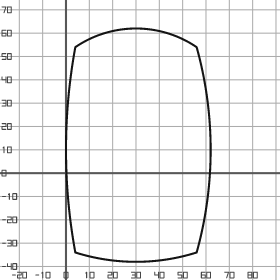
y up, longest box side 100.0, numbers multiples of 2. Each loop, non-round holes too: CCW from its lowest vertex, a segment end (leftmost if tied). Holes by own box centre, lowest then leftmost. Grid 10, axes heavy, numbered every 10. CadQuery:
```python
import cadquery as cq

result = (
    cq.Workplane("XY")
    .moveTo(4.0, -34.0)
    .threePointArc((30.0, -38.0), (56.0, -34.0))
    .threePointArc((62.0, 10.0), (56.0, 54.0))
    .threePointArc((30.0, 62.0), (4.0, 54.0))
    .threePointArc((0.0, 10.0), (4.0, -34.0))
    .close()
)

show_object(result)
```